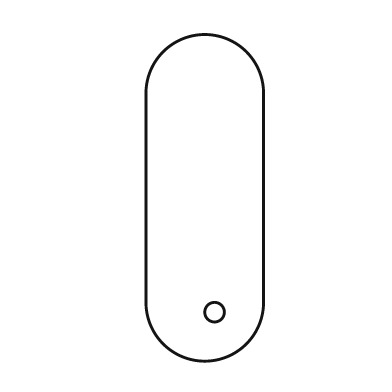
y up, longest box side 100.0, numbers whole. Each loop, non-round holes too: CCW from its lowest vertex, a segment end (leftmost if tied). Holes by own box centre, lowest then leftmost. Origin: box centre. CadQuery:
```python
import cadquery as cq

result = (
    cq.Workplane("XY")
    .moveTo(-18.0, -32.0)
    .threePointArc((0.0, -50.0), (18.0, -32.0))
    .lineTo(18.0, 32.0)
    .threePointArc((0.0, 50.0), (-18.0, 32.0))
    .close()
    .moveTo(3.0, -35.0)
    .circle(3.0)
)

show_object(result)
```